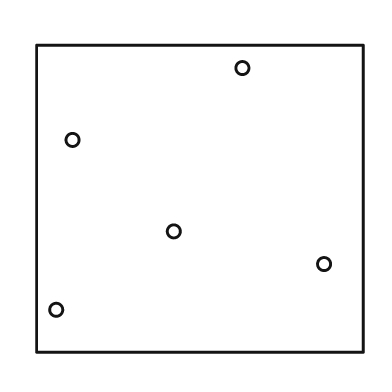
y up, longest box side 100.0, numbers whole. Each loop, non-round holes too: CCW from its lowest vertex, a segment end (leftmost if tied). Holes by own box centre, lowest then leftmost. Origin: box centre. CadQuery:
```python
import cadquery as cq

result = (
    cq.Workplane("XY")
    .moveTo(-50.0, -47.0)
    .lineTo(50.0, -47.0)
    .lineTo(50.0, 47.0)
    .lineTo(-50.0, 47.0)
    .close()
    .moveTo(-44.0, -34.0)
    .circle(2.0)
    .moveTo(38.0, -20.0)
    .circle(2.0)
    .moveTo(-8.0, -10.0)
    .circle(2.0)
    .moveTo(-39.0, 18.0)
    .circle(2.0)
    .moveTo(13.0, 40.0)
    .circle(2.0)
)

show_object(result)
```